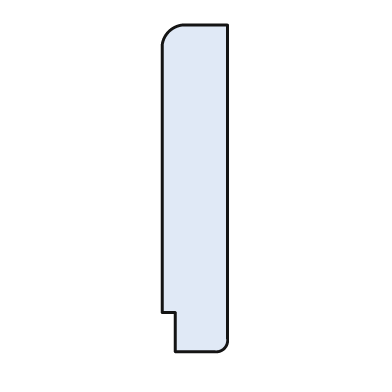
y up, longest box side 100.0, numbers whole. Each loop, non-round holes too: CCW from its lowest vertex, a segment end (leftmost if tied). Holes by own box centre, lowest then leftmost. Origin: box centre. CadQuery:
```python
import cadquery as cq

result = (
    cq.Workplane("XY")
    .moveTo(-6.0, -50.0)
    .lineTo(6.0, -50.0)
    .threePointArc((9.0, -49.0), (10.0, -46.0))
    .lineTo(10.0, 50.0)
    .lineTo(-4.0, 50.0)
    .threePointArc((-8.0, 48.0), (-10.0, 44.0))
    .lineTo(-10.0, -38.0)
    .lineTo(-6.0, -38.0)
    .close()
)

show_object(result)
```